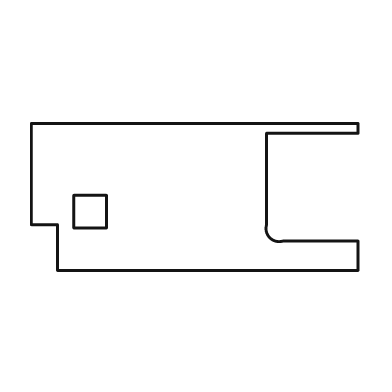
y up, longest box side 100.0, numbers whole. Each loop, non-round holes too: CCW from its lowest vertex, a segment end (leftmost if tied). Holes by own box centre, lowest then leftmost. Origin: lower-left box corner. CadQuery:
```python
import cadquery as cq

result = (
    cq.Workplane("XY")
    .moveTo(8.0, 0.0)
    .lineTo(100.0, 0.0)
    .lineTo(100.0, 9.0)
    .lineTo(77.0, 9.0)
    .threePointArc((73.0, 10.0), (72.0, 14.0))
    .lineTo(72.0, 42.0)
    .lineTo(100.0, 42.0)
    .lineTo(100.0, 45.0)
    .lineTo(0.0, 45.0)
    .lineTo(0.0, 14.0)
    .lineTo(8.0, 14.0)
    .close()
    .moveTo(13.0, 13.0)
    .lineTo(23.0, 13.0)
    .lineTo(23.0, 23.0)
    .lineTo(13.0, 23.0)
    .close()
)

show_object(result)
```